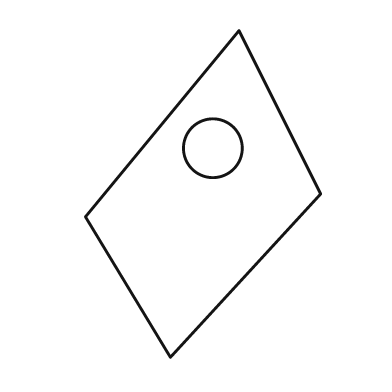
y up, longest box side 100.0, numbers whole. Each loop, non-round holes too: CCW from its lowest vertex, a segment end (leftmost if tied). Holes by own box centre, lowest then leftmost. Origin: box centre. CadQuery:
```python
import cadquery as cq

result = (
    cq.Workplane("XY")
    .moveTo(-10.0, -50.0)
    .lineTo(36.0, 0.0)
    .lineTo(11.0, 50.0)
    .lineTo(-36.0, -7.0)
    .close()
    .moveTo(3.0, 14.0)
    .circle(9.0)
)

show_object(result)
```